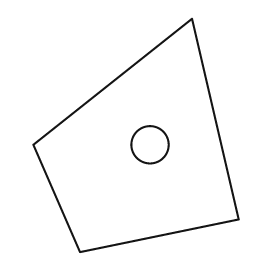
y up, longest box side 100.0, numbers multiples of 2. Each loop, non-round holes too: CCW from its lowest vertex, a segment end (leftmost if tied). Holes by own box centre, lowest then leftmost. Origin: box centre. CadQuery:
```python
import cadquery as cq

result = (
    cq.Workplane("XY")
    .moveTo(-24.0, -50.0)
    .lineTo(44.0, -36.0)
    .lineTo(24.0, 50.0)
    .lineTo(-44.0, -4.0)
    .close()
    .moveTo(6.0, -4.0)
    .circle(8.0)
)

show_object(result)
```